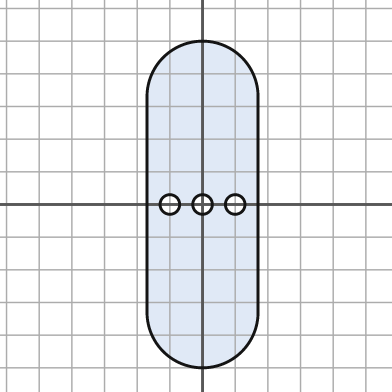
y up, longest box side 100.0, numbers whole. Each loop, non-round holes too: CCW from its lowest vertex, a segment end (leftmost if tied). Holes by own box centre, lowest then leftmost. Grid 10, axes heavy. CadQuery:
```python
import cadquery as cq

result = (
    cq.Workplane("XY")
    .moveTo(-17.0, -33.0)
    .threePointArc((0.0, -50.0), (17.0, -33.0))
    .lineTo(17.0, 33.0)
    .threePointArc((0.0, 50.0), (-17.0, 33.0))
    .close()
    .moveTo(-10.0, 0.0)
    .circle(3.0)
    .moveTo(0.0, 0.0)
    .circle(3.0)
    .moveTo(10.0, 0.0)
    .circle(3.0)
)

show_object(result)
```